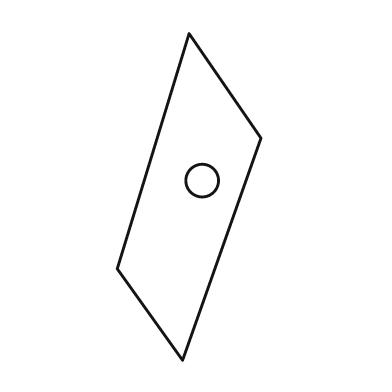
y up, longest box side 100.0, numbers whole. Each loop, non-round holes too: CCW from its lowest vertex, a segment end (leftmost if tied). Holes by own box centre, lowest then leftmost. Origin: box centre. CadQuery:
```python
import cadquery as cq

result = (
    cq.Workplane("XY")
    .moveTo(-2.0, -50.0)
    .lineTo(22.0, 18.0)
    .lineTo(0.0, 50.0)
    .lineTo(-22.0, -22.0)
    .close()
    .moveTo(4.0, 5.0)
    .circle(5.0)
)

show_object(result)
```